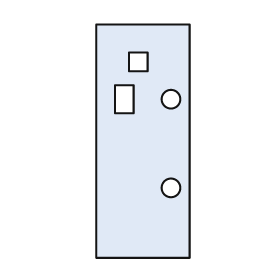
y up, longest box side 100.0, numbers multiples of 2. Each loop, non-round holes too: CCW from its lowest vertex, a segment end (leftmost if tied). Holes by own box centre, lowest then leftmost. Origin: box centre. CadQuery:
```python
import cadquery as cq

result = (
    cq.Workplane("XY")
    .moveTo(-20.0, -50.0)
    .lineTo(20.0, -50.0)
    .lineTo(20.0, 50.0)
    .lineTo(-20.0, 50.0)
    .close()
    .moveTo(12.0, -20.0)
    .circle(4.0)
    .moveTo(-12.0, 12.0)
    .lineTo(-4.0, 12.0)
    .lineTo(-4.0, 24.0)
    .lineTo(-12.0, 24.0)
    .close()
    .moveTo(12.0, 18.0)
    .circle(4.0)
    .moveTo(-6.0, 30.0)
    .lineTo(2.0, 30.0)
    .lineTo(2.0, 38.0)
    .lineTo(-6.0, 38.0)
    .close()
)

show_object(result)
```